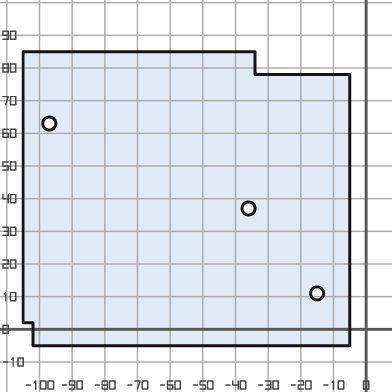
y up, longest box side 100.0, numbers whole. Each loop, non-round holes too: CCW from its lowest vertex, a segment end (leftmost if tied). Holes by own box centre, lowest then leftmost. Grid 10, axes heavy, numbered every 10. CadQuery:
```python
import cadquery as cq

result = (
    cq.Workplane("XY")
    .moveTo(-102.0, -5.0)
    .lineTo(-5.0, -5.0)
    .lineTo(-5.0, 78.0)
    .lineTo(-34.0, 78.0)
    .lineTo(-34.0, 85.0)
    .lineTo(-105.0, 85.0)
    .lineTo(-105.0, 2.0)
    .lineTo(-102.0, 2.0)
    .close()
    .moveTo(-15.0, 11.0)
    .circle(2.0)
    .moveTo(-36.0, 37.0)
    .circle(2.0)
    .moveTo(-97.0, 63.0)
    .circle(2.0)
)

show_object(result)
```